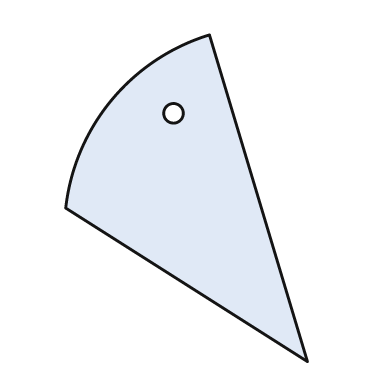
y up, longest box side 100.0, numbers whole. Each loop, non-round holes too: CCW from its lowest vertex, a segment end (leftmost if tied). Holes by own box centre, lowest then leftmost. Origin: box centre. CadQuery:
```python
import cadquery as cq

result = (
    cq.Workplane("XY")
    .moveTo(37.0, -50.0)
    .lineTo(7.0, 50.0)
    .threePointArc((-23.0, 30.0), (-37.0, -3.0))
    .close()
    .moveTo(-4.0, 26.0)
    .circle(3.0)
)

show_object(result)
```